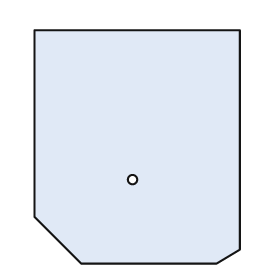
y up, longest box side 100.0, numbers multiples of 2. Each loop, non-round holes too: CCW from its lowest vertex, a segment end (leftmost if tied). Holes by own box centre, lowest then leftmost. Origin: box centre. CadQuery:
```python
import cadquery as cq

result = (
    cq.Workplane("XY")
    .moveTo(-24.0, -50.0)
    .lineTo(34.0, -50.0)
    .lineTo(44.0, -44.0)
    .lineTo(44.0, 50.0)
    .lineTo(-44.0, 50.0)
    .lineTo(-44.0, -30.0)
    .close()
    .moveTo(-2.0, -14.0)
    .circle(2.0)
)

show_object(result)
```